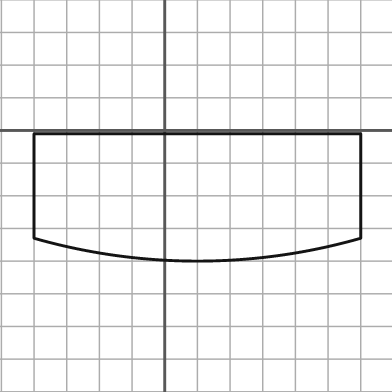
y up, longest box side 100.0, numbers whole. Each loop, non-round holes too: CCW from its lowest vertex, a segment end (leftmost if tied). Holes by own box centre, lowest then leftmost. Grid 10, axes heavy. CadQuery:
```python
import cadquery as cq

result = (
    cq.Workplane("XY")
    .moveTo(-40.0, -33.0)
    .threePointArc((10.0, -40.0), (60.0, -33.0))
    .lineTo(60.0, -1.0)
    .lineTo(-40.0, -1.0)
    .close()
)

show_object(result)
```